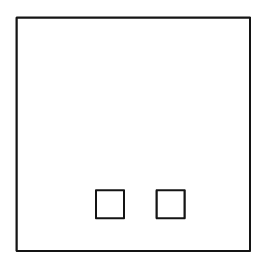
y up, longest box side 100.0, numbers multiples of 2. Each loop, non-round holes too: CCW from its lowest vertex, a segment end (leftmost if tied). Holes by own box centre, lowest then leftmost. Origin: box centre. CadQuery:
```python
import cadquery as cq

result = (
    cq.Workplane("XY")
    .moveTo(-50.0, -50.0)
    .lineTo(50.0, -50.0)
    .lineTo(50.0, 50.0)
    .lineTo(-50.0, 50.0)
    .close()
    .moveTo(-16.0, -36.0)
    .lineTo(-4.0, -36.0)
    .lineTo(-4.0, -24.0)
    .lineTo(-16.0, -24.0)
    .close()
    .moveTo(10.0, -36.0)
    .lineTo(22.0, -36.0)
    .lineTo(22.0, -24.0)
    .lineTo(10.0, -24.0)
    .close()
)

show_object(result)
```